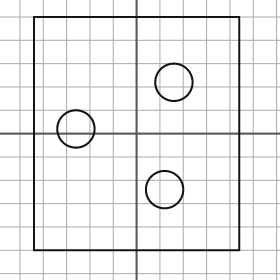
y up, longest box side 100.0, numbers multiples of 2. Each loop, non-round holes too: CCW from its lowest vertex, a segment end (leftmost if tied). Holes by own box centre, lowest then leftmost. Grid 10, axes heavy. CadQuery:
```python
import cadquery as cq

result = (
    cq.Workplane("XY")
    .moveTo(-44.0, -50.0)
    .lineTo(44.0, -50.0)
    .lineTo(44.0, 50.0)
    .lineTo(-44.0, 50.0)
    .close()
    .moveTo(12.0, -24.0)
    .circle(8.0)
    .moveTo(-26.0, 2.0)
    .circle(8.0)
    .moveTo(16.0, 22.0)
    .circle(8.0)
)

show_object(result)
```